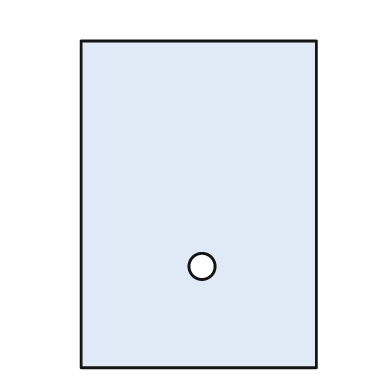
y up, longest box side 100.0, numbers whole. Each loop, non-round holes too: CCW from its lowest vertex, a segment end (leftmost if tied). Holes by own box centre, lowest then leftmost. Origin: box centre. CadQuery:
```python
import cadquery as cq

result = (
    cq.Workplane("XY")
    .moveTo(-36.0, -50.0)
    .lineTo(36.0, -50.0)
    .lineTo(36.0, 50.0)
    .lineTo(-36.0, 50.0)
    .close()
    .moveTo(1.0, -19.0)
    .circle(4.0)
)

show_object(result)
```